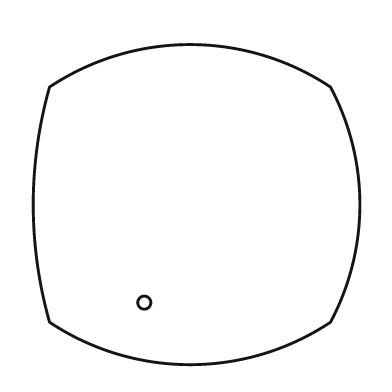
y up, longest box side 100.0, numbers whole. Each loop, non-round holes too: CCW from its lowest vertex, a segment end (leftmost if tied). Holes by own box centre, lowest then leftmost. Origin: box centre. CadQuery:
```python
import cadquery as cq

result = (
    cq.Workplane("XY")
    .moveTo(-45.0, -36.0)
    .threePointArc((-2.0, -49.0), (41.0, -36.0))
    .threePointArc((50.0, 0.0), (41.0, 36.0))
    .threePointArc((-2.0, 49.0), (-45.0, 36.0))
    .threePointArc((-50.0, 0.0), (-45.0, -36.0))
    .close()
    .moveTo(-16.0, -30.0)
    .circle(2.0)
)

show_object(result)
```